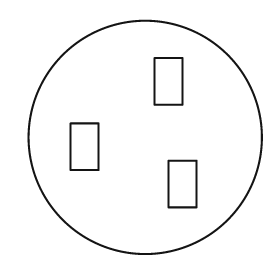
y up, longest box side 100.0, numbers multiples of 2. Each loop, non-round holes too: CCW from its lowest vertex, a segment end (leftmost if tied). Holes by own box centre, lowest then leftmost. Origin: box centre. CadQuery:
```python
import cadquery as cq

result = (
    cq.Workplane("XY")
    .moveTo(0.0, 0.0)
    .circle(50.0)
    .moveTo(10.0, -30.0)
    .lineTo(22.0, -30.0)
    .lineTo(22.0, -10.0)
    .lineTo(10.0, -10.0)
    .close()
    .moveTo(-32.0, -14.0)
    .lineTo(-20.0, -14.0)
    .lineTo(-20.0, 6.0)
    .lineTo(-32.0, 6.0)
    .close()
    .moveTo(4.0, 14.0)
    .lineTo(16.0, 14.0)
    .lineTo(16.0, 34.0)
    .lineTo(4.0, 34.0)
    .close()
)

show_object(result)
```